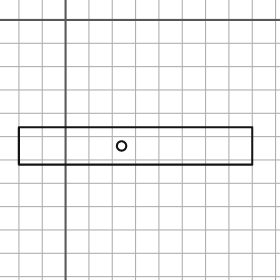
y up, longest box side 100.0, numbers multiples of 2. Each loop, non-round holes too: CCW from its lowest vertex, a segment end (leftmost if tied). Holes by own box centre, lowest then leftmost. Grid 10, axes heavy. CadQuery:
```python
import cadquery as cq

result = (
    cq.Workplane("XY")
    .moveTo(-20.0, -62.0)
    .lineTo(80.0, -62.0)
    .lineTo(80.0, -46.0)
    .lineTo(-20.0, -46.0)
    .close()
    .moveTo(24.0, -54.0)
    .circle(2.0)
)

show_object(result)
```